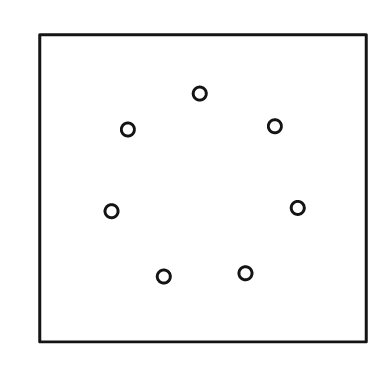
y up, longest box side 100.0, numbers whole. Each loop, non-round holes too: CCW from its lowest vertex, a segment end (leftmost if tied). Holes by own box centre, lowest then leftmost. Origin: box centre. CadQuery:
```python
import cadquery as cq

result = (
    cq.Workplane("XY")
    .moveTo(-50.0, -47.0)
    .lineTo(50.0, -47.0)
    .lineTo(50.0, 47.0)
    .lineTo(-50.0, 47.0)
    .close()
    .moveTo(-12.0, -27.0)
    .circle(2.0)
    .moveTo(13.0, -26.0)
    .circle(2.0)
    .moveTo(-28.0, -7.0)
    .circle(2.0)
    .moveTo(29.0, -6.0)
    .circle(2.0)
    .moveTo(-23.0, 18.0)
    .circle(2.0)
    .moveTo(22.0, 19.0)
    .circle(2.0)
    .moveTo(-1.0, 29.0)
    .circle(2.0)
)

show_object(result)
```